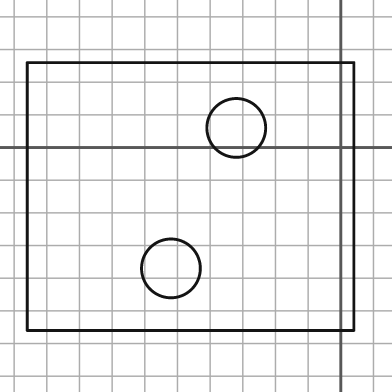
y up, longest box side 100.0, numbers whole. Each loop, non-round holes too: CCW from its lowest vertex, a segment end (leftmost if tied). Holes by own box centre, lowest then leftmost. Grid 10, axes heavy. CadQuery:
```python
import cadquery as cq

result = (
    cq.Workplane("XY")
    .moveTo(-96.0, -56.0)
    .lineTo(4.0, -56.0)
    .lineTo(4.0, 26.0)
    .lineTo(-96.0, 26.0)
    .close()
    .moveTo(-52.0, -37.0)
    .circle(9.0)
    .moveTo(-32.0, 6.0)
    .circle(9.0)
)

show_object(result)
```